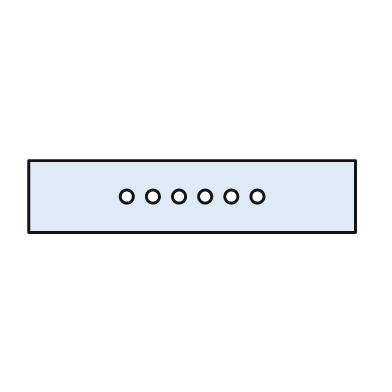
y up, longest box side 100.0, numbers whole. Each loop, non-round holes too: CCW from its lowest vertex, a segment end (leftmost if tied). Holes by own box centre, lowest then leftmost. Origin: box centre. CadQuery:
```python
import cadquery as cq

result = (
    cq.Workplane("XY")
    .moveTo(-50.0, -11.0)
    .lineTo(50.0, -11.0)
    .lineTo(50.0, 11.0)
    .lineTo(-50.0, 11.0)
    .close()
    .moveTo(-20.0, 0.0)
    .circle(2.0)
    .moveTo(-12.0, 0.0)
    .circle(2.0)
    .moveTo(-4.0, 0.0)
    .circle(2.0)
    .moveTo(4.0, 0.0)
    .circle(2.0)
    .moveTo(12.0, 0.0)
    .circle(2.0)
    .moveTo(20.0, 0.0)
    .circle(2.0)
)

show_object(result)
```